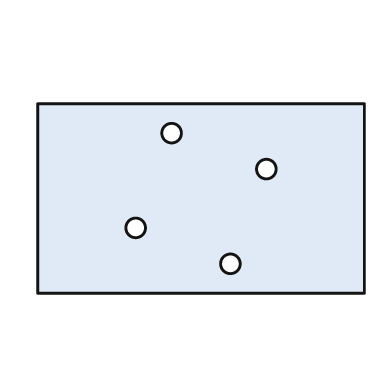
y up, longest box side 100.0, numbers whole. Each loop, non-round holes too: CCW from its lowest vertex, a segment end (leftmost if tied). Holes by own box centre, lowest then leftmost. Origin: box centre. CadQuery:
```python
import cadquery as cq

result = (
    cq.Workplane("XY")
    .moveTo(-50.0, -29.0)
    .lineTo(50.0, -29.0)
    .lineTo(50.0, 29.0)
    .lineTo(-50.0, 29.0)
    .close()
    .moveTo(9.0, -20.0)
    .circle(3.0)
    .moveTo(-20.0, -9.0)
    .circle(3.0)
    .moveTo(20.0, 9.0)
    .circle(3.0)
    .moveTo(-9.0, 20.0)
    .circle(3.0)
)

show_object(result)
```